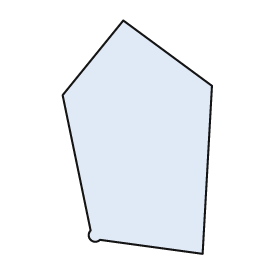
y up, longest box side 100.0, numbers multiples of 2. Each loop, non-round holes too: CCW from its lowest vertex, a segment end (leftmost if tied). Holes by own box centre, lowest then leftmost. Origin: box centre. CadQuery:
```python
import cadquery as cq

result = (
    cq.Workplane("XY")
    .moveTo(28.0, -50.0)
    .lineTo(32.0, 22.0)
    .lineTo(-6.0, 50.0)
    .lineTo(-32.0, 18.0)
    .lineTo(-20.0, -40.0)
    .threePointArc((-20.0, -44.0), (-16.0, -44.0))
    .close()
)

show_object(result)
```